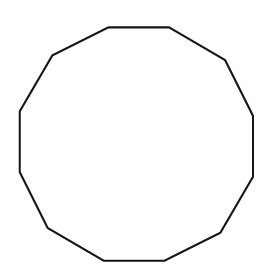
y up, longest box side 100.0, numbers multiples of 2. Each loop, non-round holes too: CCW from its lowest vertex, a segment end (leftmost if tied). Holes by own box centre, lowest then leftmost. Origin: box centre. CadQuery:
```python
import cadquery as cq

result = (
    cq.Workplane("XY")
    .moveTo(-14.0, -50.0)
    .lineTo(12.0, -50.0)
    .lineTo(36.0, -38.0)
    .lineTo(50.0, -14.0)
    .lineTo(50.0, 12.0)
    .lineTo(38.0, 36.0)
    .lineTo(14.0, 50.0)
    .lineTo(-12.0, 50.0)
    .lineTo(-36.0, 38.0)
    .lineTo(-50.0, 14.0)
    .lineTo(-50.0, -12.0)
    .lineTo(-38.0, -36.0)
    .close()
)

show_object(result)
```